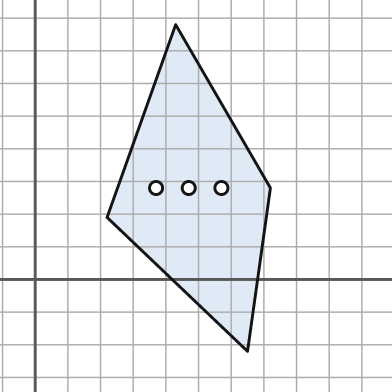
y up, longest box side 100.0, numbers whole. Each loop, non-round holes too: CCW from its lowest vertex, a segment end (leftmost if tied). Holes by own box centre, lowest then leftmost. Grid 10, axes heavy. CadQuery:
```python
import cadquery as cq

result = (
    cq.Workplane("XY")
    .moveTo(65.0, -22.0)
    .lineTo(72.0, 28.0)
    .lineTo(43.0, 78.0)
    .lineTo(22.0, 19.0)
    .close()
    .moveTo(37.0, 28.0)
    .circle(2.0)
    .moveTo(47.0, 28.0)
    .circle(2.0)
    .moveTo(57.0, 28.0)
    .circle(2.0)
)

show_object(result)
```